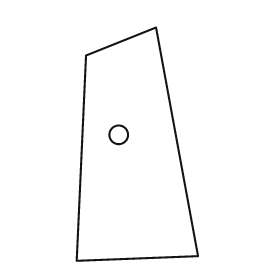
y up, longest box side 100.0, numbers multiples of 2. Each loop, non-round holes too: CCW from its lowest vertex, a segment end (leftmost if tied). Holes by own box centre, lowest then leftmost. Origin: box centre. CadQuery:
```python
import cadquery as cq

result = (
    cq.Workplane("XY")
    .moveTo(-26.0, -50.0)
    .lineTo(26.0, -48.0)
    .lineTo(8.0, 50.0)
    .lineTo(-22.0, 38.0)
    .close()
    .moveTo(-8.0, 4.0)
    .circle(4.0)
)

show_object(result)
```